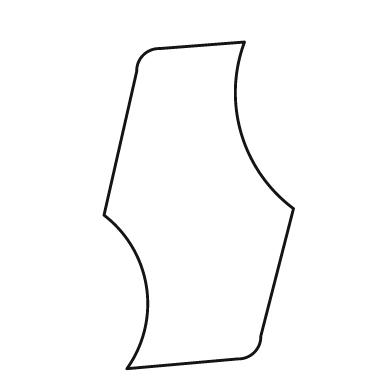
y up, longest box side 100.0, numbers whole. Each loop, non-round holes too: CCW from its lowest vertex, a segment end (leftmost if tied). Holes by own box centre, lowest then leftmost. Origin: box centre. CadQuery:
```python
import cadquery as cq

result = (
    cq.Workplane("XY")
    .moveTo(-22.0, -50.0)
    .lineTo(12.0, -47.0)
    .threePointArc((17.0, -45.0), (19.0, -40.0))
    .lineTo(29.0, -1.0)
    .threePointArc((13.0, 22.0), (14.0, 50.0))
    .lineTo(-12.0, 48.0)
    .threePointArc((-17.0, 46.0), (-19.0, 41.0))
    .lineTo(-29.0, -3.0)
    .threePointArc((-16.0, -25.0), (-22.0, -50.0))
    .close()
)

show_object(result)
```